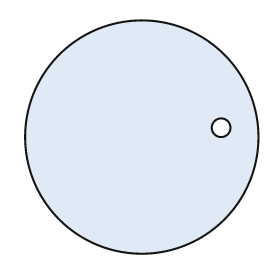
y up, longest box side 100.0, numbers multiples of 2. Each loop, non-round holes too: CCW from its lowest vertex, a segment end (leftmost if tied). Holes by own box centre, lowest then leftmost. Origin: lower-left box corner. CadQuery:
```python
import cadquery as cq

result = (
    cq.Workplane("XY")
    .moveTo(50.0, 50.0)
    .circle(50.0)
    .moveTo(84.0, 54.0)
    .circle(4.0)
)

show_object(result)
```